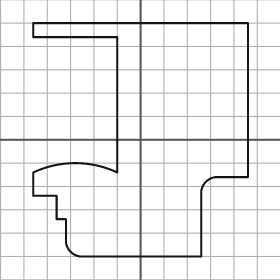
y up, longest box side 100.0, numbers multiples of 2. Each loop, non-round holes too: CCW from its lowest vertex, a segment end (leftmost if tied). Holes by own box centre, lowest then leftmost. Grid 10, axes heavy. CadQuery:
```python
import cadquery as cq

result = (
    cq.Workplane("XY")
    .moveTo(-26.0, -50.0)
    .lineTo(26.0, -50.0)
    .lineTo(26.0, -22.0)
    .threePointArc((28.0, -18.0), (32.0, -16.0))
    .lineTo(46.0, -16.0)
    .lineTo(46.0, 50.0)
    .lineTo(-46.0, 50.0)
    .lineTo(-46.0, 44.0)
    .lineTo(-10.0, 44.0)
    .lineTo(-10.0, -14.0)
    .threePointArc((-28.0, -10.0), (-46.0, -14.0))
    .lineTo(-46.0, -24.0)
    .lineTo(-36.0, -24.0)
    .lineTo(-36.0, -34.0)
    .lineTo(-32.0, -34.0)
    .lineTo(-32.0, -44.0)
    .threePointArc((-30.0, -48.0), (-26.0, -50.0))
    .close()
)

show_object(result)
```